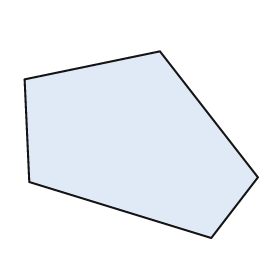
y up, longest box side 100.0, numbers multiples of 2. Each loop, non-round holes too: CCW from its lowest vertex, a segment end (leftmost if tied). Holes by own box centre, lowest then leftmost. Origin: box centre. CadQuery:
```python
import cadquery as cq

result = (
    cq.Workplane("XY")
    .moveTo(30.0, -40.0)
    .lineTo(50.0, -14.0)
    .lineTo(8.0, 40.0)
    .lineTo(-50.0, 28.0)
    .lineTo(-48.0, -16.0)
    .close()
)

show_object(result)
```